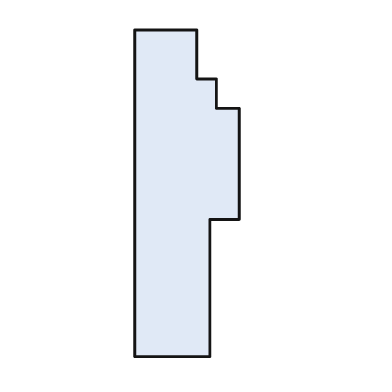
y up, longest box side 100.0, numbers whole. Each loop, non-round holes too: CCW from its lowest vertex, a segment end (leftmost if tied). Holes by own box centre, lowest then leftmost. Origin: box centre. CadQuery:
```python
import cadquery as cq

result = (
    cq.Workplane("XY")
    .moveTo(-16.0, -50.0)
    .lineTo(7.0, -50.0)
    .lineTo(7.0, -8.0)
    .lineTo(16.0, -8.0)
    .lineTo(16.0, 26.0)
    .lineTo(9.0, 26.0)
    .lineTo(9.0, 35.0)
    .lineTo(3.0, 35.0)
    .lineTo(3.0, 50.0)
    .lineTo(-16.0, 50.0)
    .close()
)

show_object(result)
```